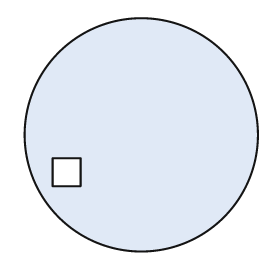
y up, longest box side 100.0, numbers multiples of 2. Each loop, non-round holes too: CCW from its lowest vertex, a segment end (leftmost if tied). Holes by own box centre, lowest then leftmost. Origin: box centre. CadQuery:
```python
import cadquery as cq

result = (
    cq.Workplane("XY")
    .moveTo(0.0, 0.0)
    .circle(50.0)
    .moveTo(-38.0, -22.0)
    .lineTo(-26.0, -22.0)
    .lineTo(-26.0, -10.0)
    .lineTo(-38.0, -10.0)
    .close()
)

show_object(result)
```